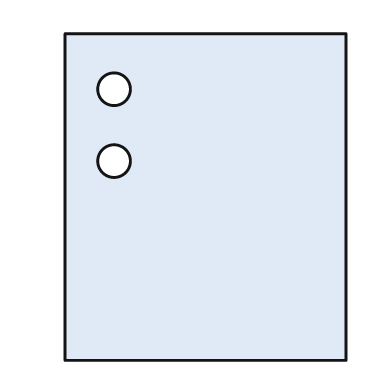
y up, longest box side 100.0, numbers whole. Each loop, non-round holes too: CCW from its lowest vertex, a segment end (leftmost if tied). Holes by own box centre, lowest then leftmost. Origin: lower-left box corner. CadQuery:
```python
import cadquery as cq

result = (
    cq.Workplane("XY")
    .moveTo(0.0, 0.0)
    .lineTo(86.0, 0.0)
    .lineTo(86.0, 100.0)
    .lineTo(0.0, 100.0)
    .close()
    .moveTo(15.0, 61.0)
    .circle(5.0)
    .moveTo(15.0, 83.0)
    .circle(5.0)
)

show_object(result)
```